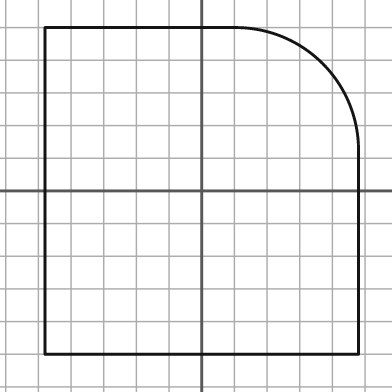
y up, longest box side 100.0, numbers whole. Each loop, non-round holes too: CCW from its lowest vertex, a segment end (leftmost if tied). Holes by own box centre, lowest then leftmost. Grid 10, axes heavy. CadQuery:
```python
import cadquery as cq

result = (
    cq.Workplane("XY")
    .moveTo(-48.0, -50.0)
    .lineTo(48.0, -50.0)
    .lineTo(48.0, 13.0)
    .threePointArc((37.0, 39.0), (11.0, 50.0))
    .lineTo(-48.0, 50.0)
    .close()
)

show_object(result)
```